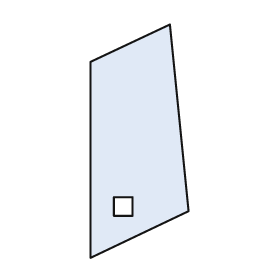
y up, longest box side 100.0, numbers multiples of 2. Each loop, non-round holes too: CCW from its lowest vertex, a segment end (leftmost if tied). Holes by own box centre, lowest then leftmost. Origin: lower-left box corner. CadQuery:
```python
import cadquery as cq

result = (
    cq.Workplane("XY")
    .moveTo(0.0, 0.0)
    .lineTo(42.0, 20.0)
    .lineTo(34.0, 100.0)
    .lineTo(0.0, 84.0)
    .close()
    .moveTo(10.0, 18.0)
    .lineTo(18.0, 18.0)
    .lineTo(18.0, 26.0)
    .lineTo(10.0, 26.0)
    .close()
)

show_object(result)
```